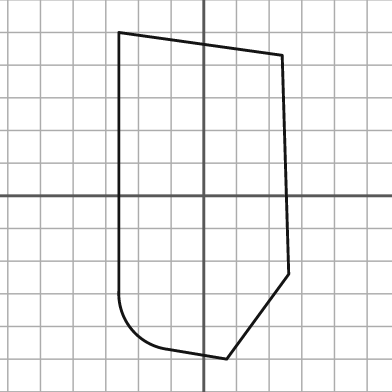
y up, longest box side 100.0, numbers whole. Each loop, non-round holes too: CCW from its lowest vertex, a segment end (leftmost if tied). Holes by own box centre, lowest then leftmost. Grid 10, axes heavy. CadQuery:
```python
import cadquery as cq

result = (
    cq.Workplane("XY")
    .moveTo(7.0, -50.0)
    .lineTo(26.0, -24.0)
    .lineTo(24.0, 43.0)
    .lineTo(-26.0, 50.0)
    .lineTo(-26.0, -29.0)
    .threePointArc((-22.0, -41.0), (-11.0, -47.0))
    .close()
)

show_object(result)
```